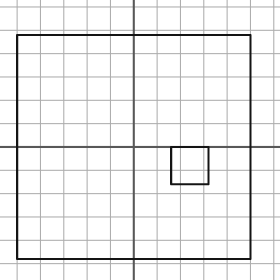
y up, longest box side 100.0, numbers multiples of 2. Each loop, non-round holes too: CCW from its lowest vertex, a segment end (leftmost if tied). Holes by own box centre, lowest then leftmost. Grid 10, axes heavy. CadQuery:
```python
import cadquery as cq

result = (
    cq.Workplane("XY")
    .moveTo(-50.0, -48.0)
    .lineTo(50.0, -48.0)
    .lineTo(50.0, 48.0)
    .lineTo(-50.0, 48.0)
    .close()
    .moveTo(16.0, -16.0)
    .lineTo(32.0, -16.0)
    .lineTo(32.0, 0.0)
    .lineTo(16.0, 0.0)
    .close()
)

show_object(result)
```